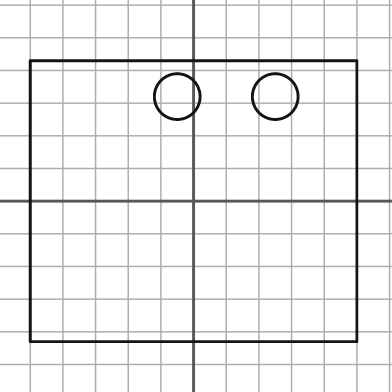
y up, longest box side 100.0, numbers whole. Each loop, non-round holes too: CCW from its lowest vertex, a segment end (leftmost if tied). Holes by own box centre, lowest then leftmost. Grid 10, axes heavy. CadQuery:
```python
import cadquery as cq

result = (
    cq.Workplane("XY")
    .moveTo(-50.0, -43.0)
    .lineTo(50.0, -43.0)
    .lineTo(50.0, 43.0)
    .lineTo(-50.0, 43.0)
    .close()
    .moveTo(-5.0, 32.0)
    .circle(7.0)
    .moveTo(25.0, 32.0)
    .circle(7.0)
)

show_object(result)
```